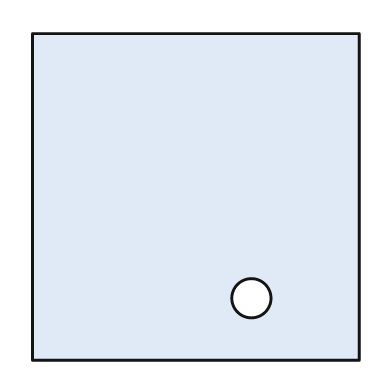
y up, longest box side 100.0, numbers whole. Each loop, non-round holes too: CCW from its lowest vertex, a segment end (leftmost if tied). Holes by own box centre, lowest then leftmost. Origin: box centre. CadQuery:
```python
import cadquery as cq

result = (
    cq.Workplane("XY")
    .moveTo(-50.0, -50.0)
    .lineTo(50.0, -50.0)
    .lineTo(50.0, 50.0)
    .lineTo(-50.0, 50.0)
    .close()
    .moveTo(17.0, -31.0)
    .circle(6.0)
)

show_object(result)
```